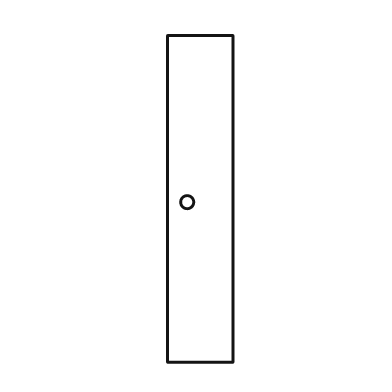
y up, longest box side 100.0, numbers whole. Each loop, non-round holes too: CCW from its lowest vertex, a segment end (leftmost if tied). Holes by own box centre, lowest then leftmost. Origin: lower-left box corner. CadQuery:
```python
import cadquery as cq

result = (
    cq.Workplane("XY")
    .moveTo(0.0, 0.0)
    .lineTo(20.0, 0.0)
    .lineTo(20.0, 100.0)
    .lineTo(0.0, 100.0)
    .close()
    .moveTo(6.0, 49.0)
    .circle(2.0)
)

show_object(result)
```